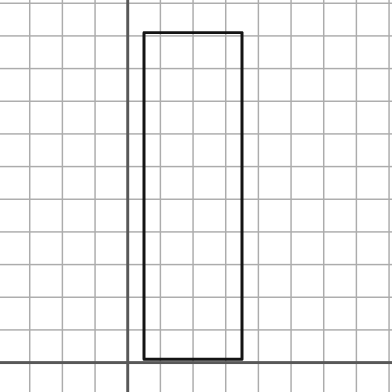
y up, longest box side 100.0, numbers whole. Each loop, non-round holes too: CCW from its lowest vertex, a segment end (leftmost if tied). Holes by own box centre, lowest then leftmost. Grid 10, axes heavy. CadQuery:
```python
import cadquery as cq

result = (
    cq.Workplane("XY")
    .moveTo(5.0, 1.0)
    .lineTo(35.0, 1.0)
    .lineTo(35.0, 101.0)
    .lineTo(5.0, 101.0)
    .close()
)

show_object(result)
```